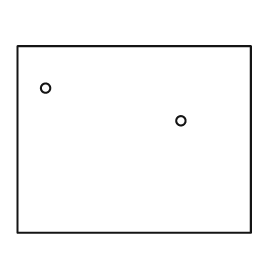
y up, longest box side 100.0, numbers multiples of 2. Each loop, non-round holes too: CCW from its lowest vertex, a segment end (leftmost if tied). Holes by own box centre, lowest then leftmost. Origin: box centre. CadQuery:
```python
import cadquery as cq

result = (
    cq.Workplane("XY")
    .moveTo(-50.0, -40.0)
    .lineTo(50.0, -40.0)
    .lineTo(50.0, 40.0)
    .lineTo(-50.0, 40.0)
    .close()
    .moveTo(20.0, 8.0)
    .circle(2.0)
    .moveTo(-38.0, 22.0)
    .circle(2.0)
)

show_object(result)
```